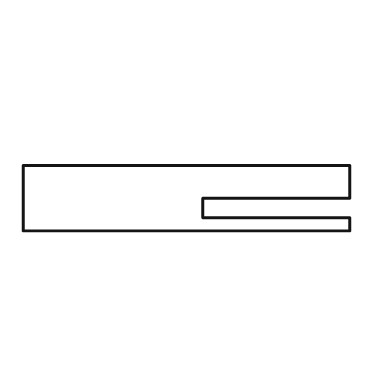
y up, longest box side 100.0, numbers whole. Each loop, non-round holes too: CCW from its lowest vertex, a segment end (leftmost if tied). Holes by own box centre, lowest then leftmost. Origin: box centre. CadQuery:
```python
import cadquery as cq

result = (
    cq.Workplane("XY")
    .moveTo(-50.0, -10.0)
    .lineTo(50.0, -10.0)
    .lineTo(50.0, -6.0)
    .lineTo(5.0, -6.0)
    .lineTo(5.0, 0.0)
    .lineTo(50.0, 0.0)
    .lineTo(50.0, 10.0)
    .lineTo(-50.0, 10.0)
    .close()
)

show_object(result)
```